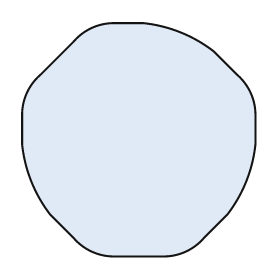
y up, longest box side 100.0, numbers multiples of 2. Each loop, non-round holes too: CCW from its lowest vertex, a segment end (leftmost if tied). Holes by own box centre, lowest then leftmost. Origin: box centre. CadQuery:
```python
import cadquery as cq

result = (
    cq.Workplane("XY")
    .moveTo(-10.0, -50.0)
    .lineTo(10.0, -50.0)
    .threePointArc((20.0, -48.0), (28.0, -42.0))
    .lineTo(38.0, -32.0)
    .threePointArc((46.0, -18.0), (50.0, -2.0))
    .lineTo(50.0, 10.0)
    .threePointArc((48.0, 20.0), (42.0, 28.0))
    .lineTo(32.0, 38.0)
    .threePointArc((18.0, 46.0), (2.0, 50.0))
    .lineTo(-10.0, 50.0)
    .threePointArc((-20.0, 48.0), (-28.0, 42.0))
    .lineTo(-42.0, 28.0)
    .threePointArc((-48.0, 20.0), (-50.0, 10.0))
    .lineTo(-50.0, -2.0)
    .threePointArc((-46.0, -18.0), (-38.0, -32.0))
    .lineTo(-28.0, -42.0)
    .threePointArc((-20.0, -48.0), (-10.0, -50.0))
    .close()
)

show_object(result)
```